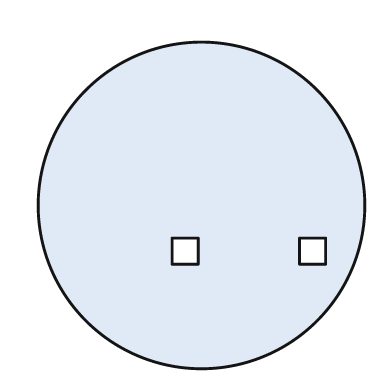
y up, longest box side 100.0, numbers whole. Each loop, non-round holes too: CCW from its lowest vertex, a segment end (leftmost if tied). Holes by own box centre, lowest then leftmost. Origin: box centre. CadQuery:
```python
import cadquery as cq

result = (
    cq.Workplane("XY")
    .moveTo(0.0, 0.0)
    .circle(50.0)
    .moveTo(-9.0, -18.0)
    .lineTo(-1.0, -18.0)
    .lineTo(-1.0, -10.0)
    .lineTo(-9.0, -10.0)
    .close()
    .moveTo(30.0, -18.0)
    .lineTo(38.0, -18.0)
    .lineTo(38.0, -10.0)
    .lineTo(30.0, -10.0)
    .close()
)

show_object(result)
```